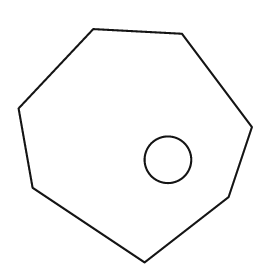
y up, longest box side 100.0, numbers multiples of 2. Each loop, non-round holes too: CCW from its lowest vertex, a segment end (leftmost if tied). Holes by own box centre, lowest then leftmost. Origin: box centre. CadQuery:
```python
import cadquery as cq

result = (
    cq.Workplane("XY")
    .moveTo(4.0, -50.0)
    .lineTo(40.0, -22.0)
    .lineTo(50.0, 8.0)
    .lineTo(20.0, 48.0)
    .lineTo(-18.0, 50.0)
    .lineTo(-50.0, 16.0)
    .lineTo(-44.0, -18.0)
    .close()
    .moveTo(14.0, -6.0)
    .circle(10.0)
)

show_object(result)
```